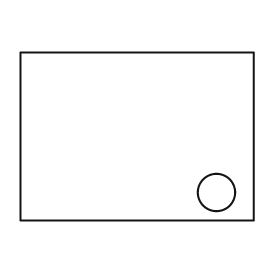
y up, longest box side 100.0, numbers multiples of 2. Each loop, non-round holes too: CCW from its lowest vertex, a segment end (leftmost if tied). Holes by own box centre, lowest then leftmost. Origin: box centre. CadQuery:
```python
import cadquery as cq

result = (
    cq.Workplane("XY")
    .moveTo(-50.0, -36.0)
    .lineTo(50.0, -36.0)
    .lineTo(50.0, 36.0)
    .lineTo(-50.0, 36.0)
    .close()
    .moveTo(34.0, -24.0)
    .circle(8.0)
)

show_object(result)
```